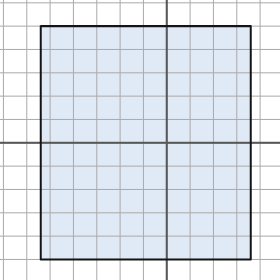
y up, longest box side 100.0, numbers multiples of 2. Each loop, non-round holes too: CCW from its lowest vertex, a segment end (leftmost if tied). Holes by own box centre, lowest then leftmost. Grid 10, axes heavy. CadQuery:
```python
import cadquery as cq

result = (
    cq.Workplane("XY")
    .moveTo(-54.0, -50.0)
    .lineTo(36.0, -50.0)
    .lineTo(36.0, 50.0)
    .lineTo(-54.0, 50.0)
    .close()
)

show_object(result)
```